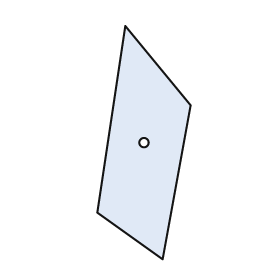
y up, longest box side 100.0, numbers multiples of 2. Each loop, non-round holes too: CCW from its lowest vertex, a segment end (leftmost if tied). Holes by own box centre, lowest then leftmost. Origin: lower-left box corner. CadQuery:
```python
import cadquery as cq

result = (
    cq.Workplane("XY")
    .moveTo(28.0, 0.0)
    .lineTo(40.0, 66.0)
    .lineTo(12.0, 100.0)
    .lineTo(0.0, 20.0)
    .close()
    .moveTo(20.0, 50.0)
    .circle(2.0)
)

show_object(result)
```